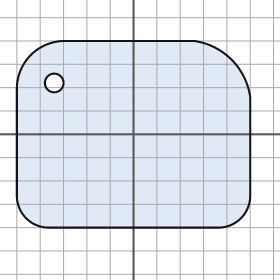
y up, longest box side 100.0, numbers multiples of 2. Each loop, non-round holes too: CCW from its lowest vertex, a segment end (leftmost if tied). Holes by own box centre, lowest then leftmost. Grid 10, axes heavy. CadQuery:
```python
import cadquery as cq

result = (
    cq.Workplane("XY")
    .moveTo(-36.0, -40.0)
    .lineTo(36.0, -40.0)
    .threePointArc((46.0, -36.0), (50.0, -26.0))
    .lineTo(50.0, 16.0)
    .threePointArc((42.0, 32.0), (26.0, 40.0))
    .lineTo(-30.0, 40.0)
    .threePointArc((-44.0, 34.0), (-50.0, 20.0))
    .lineTo(-50.0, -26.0)
    .threePointArc((-46.0, -36.0), (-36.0, -40.0))
    .close()
    .moveTo(-34.0, 22.0)
    .circle(4.0)
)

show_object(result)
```